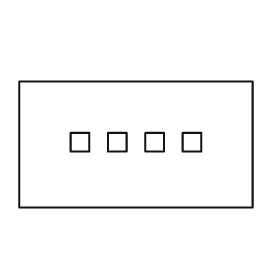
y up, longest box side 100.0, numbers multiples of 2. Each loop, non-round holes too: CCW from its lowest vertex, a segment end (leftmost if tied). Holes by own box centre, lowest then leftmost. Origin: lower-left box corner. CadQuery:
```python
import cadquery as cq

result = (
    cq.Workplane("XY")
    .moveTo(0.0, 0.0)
    .lineTo(100.0, 0.0)
    .lineTo(100.0, 54.0)
    .lineTo(0.0, 54.0)
    .close()
    .moveTo(22.0, 24.0)
    .lineTo(30.0, 24.0)
    .lineTo(30.0, 32.0)
    .lineTo(22.0, 32.0)
    .close()
    .moveTo(38.0, 24.0)
    .lineTo(46.0, 24.0)
    .lineTo(46.0, 32.0)
    .lineTo(38.0, 32.0)
    .close()
    .moveTo(54.0, 24.0)
    .lineTo(62.0, 24.0)
    .lineTo(62.0, 32.0)
    .lineTo(54.0, 32.0)
    .close()
    .moveTo(70.0, 24.0)
    .lineTo(78.0, 24.0)
    .lineTo(78.0, 32.0)
    .lineTo(70.0, 32.0)
    .close()
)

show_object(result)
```